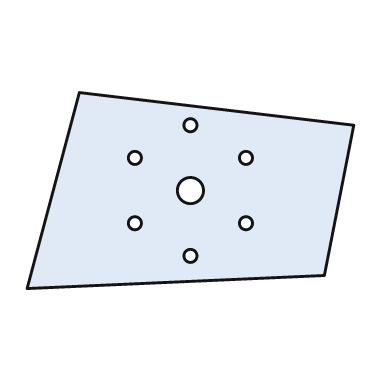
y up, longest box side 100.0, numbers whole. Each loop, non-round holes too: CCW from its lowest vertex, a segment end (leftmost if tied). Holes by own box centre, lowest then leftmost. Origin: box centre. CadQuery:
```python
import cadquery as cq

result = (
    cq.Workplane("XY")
    .moveTo(-50.0, -30.0)
    .lineTo(41.0, -26.0)
    .lineTo(50.0, 20.0)
    .lineTo(-34.0, 30.0)
    .close()
    .moveTo(0.0, -20.0)
    .circle(2.0)
    .moveTo(-17.0, -10.0)
    .circle(2.0)
    .moveTo(17.0, -10.0)
    .circle(2.0)
    .moveTo(0.0, 0.0)
    .circle(4.0)
    .moveTo(-17.0, 10.0)
    .circle(2.0)
    .moveTo(17.0, 10.0)
    .circle(2.0)
    .moveTo(0.0, 20.0)
    .circle(2.0)
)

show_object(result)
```